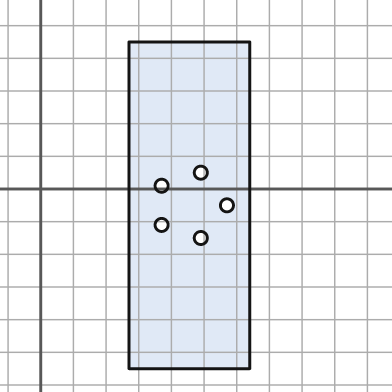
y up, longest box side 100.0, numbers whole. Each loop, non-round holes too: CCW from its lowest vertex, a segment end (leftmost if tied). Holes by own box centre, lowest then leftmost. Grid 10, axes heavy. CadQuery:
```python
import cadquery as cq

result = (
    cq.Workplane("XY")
    .moveTo(27.0, -55.0)
    .lineTo(64.0, -55.0)
    .lineTo(64.0, 45.0)
    .lineTo(27.0, 45.0)
    .close()
    .moveTo(49.0, -15.0)
    .circle(2.0)
    .moveTo(37.0, -11.0)
    .circle(2.0)
    .moveTo(57.0, -5.0)
    .circle(2.0)
    .moveTo(37.0, 1.0)
    .circle(2.0)
    .moveTo(49.0, 5.0)
    .circle(2.0)
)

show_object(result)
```